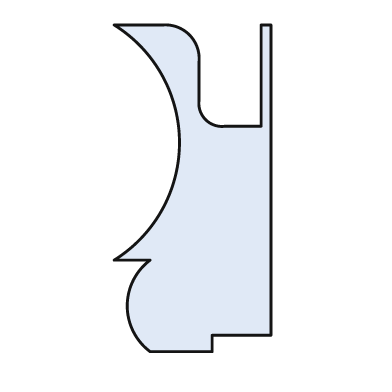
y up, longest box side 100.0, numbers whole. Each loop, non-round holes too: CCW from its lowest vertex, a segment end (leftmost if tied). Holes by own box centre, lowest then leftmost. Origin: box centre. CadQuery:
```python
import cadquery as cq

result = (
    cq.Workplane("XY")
    .moveTo(-13.0, -50.0)
    .lineTo(6.0, -50.0)
    .lineTo(6.0, -45.0)
    .lineTo(24.0, -45.0)
    .lineTo(24.0, 50.0)
    .lineTo(21.0, 50.0)
    .lineTo(21.0, 19.0)
    .lineTo(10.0, 19.0)
    .threePointArc((4.0, 21.0), (2.0, 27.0))
    .lineTo(2.0, 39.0)
    .threePointArc((-1.0, 47.0), (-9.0, 50.0))
    .lineTo(-24.0, 50.0)
    .threePointArc((-4.0, 14.0), (-24.0, -22.0))
    .lineTo(-13.0, -22.0)
    .threePointArc((-20.0, -36.0), (-13.0, -50.0))
    .close()
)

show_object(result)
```